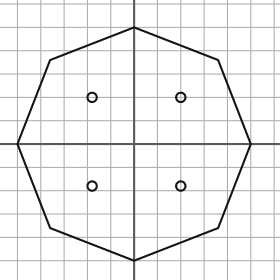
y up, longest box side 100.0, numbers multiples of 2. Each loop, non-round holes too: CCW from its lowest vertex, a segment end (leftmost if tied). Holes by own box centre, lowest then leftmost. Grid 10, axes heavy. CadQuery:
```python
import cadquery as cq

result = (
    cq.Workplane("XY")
    .moveTo(0.0, -50.0)
    .lineTo(36.0, -36.0)
    .lineTo(50.0, 0.0)
    .lineTo(36.0, 36.0)
    .lineTo(0.0, 50.0)
    .lineTo(-36.0, 36.0)
    .lineTo(-50.0, 0.0)
    .lineTo(-36.0, -36.0)
    .close()
    .moveTo(-18.0, -18.0)
    .circle(2.0)
    .moveTo(20.0, -18.0)
    .circle(2.0)
    .moveTo(-18.0, 20.0)
    .circle(2.0)
    .moveTo(20.0, 20.0)
    .circle(2.0)
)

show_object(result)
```